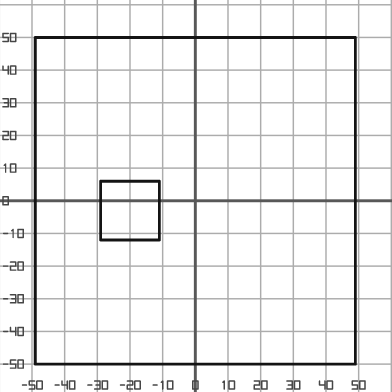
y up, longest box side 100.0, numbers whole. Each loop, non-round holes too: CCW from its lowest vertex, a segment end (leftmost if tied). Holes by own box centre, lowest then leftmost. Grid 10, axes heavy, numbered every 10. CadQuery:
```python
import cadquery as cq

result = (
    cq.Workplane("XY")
    .moveTo(-49.0, -50.0)
    .lineTo(49.0, -50.0)
    .lineTo(49.0, 50.0)
    .lineTo(-49.0, 50.0)
    .close()
    .moveTo(-29.0, -12.0)
    .lineTo(-11.0, -12.0)
    .lineTo(-11.0, 6.0)
    .lineTo(-29.0, 6.0)
    .close()
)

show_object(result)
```